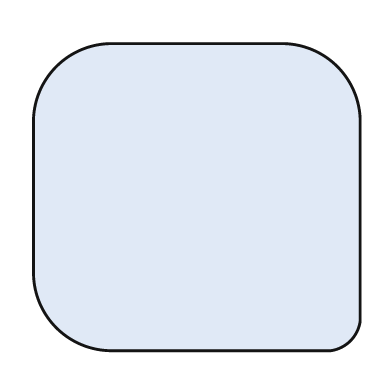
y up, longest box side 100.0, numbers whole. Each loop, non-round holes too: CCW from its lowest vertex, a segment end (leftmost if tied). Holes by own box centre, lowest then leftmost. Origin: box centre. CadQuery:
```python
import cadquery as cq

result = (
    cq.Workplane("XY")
    .moveTo(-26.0, -47.0)
    .lineTo(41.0, -47.0)
    .threePointArc((47.0, -44.0), (50.0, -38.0))
    .lineTo(50.0, 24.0)
    .threePointArc((43.0, 40.0), (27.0, 47.0))
    .lineTo(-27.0, 47.0)
    .threePointArc((-43.0, 40.0), (-50.0, 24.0))
    .lineTo(-50.0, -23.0)
    .threePointArc((-43.0, -40.0), (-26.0, -47.0))
    .close()
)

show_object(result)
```